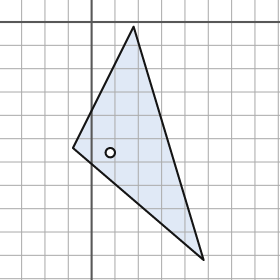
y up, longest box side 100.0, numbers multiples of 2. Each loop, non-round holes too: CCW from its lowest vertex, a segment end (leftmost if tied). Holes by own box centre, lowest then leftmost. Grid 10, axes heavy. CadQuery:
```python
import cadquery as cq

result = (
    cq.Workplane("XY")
    .moveTo(48.0, -102.0)
    .lineTo(18.0, -2.0)
    .lineTo(-8.0, -54.0)
    .close()
    .moveTo(8.0, -56.0)
    .circle(2.0)
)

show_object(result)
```